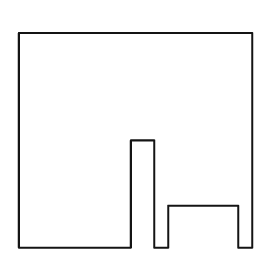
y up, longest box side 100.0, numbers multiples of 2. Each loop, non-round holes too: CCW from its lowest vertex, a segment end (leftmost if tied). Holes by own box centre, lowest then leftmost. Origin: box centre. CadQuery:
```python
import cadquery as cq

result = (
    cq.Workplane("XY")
    .moveTo(-50.0, -46.0)
    .lineTo(-2.0, -46.0)
    .lineTo(-2.0, 0.0)
    .lineTo(8.0, 0.0)
    .lineTo(8.0, -46.0)
    .lineTo(14.0, -46.0)
    .lineTo(14.0, -28.0)
    .lineTo(44.0, -28.0)
    .lineTo(44.0, -46.0)
    .lineTo(50.0, -46.0)
    .lineTo(50.0, 46.0)
    .lineTo(-50.0, 46.0)
    .close()
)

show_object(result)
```